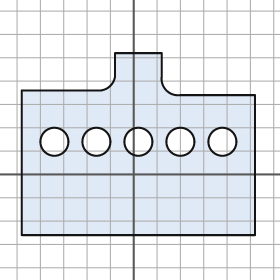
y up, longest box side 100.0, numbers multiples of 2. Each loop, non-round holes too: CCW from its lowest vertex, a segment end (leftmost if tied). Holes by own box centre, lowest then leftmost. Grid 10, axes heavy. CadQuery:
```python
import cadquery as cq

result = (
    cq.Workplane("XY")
    .moveTo(-48.0, -26.0)
    .lineTo(52.0, -26.0)
    .lineTo(52.0, 34.0)
    .lineTo(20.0, 34.0)
    .threePointArc((14.0, 36.0), (12.0, 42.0))
    .lineTo(12.0, 52.0)
    .lineTo(-8.0, 52.0)
    .lineTo(-8.0, 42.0)
    .threePointArc((-10.0, 38.0), (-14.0, 36.0))
    .lineTo(-48.0, 36.0)
    .close()
    .moveTo(-34.0, 14.0)
    .circle(6.0)
    .moveTo(-16.0, 14.0)
    .circle(6.0)
    .moveTo(2.0, 14.0)
    .circle(6.0)
    .moveTo(20.0, 14.0)
    .circle(6.0)
    .moveTo(38.0, 14.0)
    .circle(6.0)
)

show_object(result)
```